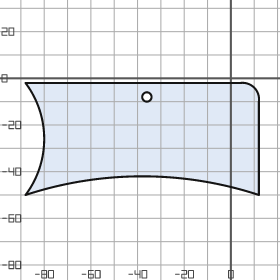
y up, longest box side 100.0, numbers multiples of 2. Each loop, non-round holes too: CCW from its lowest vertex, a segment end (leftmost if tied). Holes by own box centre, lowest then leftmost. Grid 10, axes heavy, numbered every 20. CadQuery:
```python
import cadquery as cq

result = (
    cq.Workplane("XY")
    .moveTo(-88.0, -50.0)
    .threePointArc((-38.0, -42.0), (12.0, -50.0))
    .lineTo(12.0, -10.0)
    .threePointArc((10.0, -4.0), (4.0, -2.0))
    .lineTo(-88.0, -2.0)
    .threePointArc((-80.0, -26.0), (-88.0, -50.0))
    .close()
    .moveTo(-36.0, -8.0)
    .circle(2.0)
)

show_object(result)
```